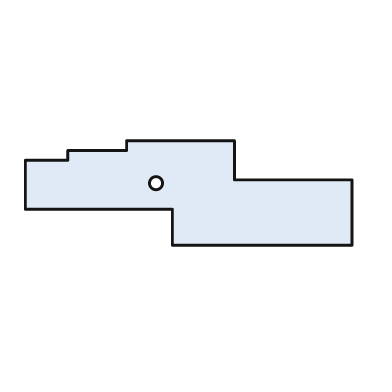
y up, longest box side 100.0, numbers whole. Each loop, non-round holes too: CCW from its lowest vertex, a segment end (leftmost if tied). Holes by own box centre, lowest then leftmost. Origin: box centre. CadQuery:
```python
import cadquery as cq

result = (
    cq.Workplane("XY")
    .moveTo(-5.0, -16.0)
    .lineTo(50.0, -16.0)
    .lineTo(50.0, 4.0)
    .lineTo(14.0, 4.0)
    .lineTo(14.0, 16.0)
    .lineTo(-19.0, 16.0)
    .lineTo(-19.0, 13.0)
    .lineTo(-37.0, 13.0)
    .lineTo(-37.0, 10.0)
    .lineTo(-50.0, 10.0)
    .lineTo(-50.0, -5.0)
    .lineTo(-5.0, -5.0)
    .close()
    .moveTo(-10.0, 3.0)
    .circle(2.0)
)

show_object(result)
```